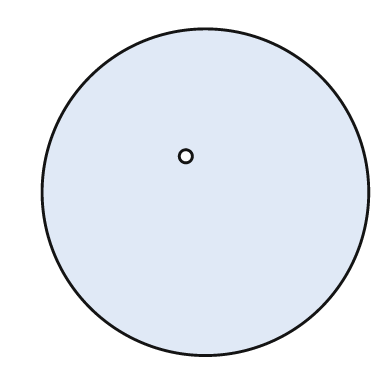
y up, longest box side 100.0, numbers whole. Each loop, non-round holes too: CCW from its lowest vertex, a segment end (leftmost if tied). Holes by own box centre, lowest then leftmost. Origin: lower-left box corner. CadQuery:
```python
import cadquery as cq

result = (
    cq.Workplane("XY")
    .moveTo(50.0, 50.0)
    .circle(50.0)
    .moveTo(44.0, 61.0)
    .circle(2.0)
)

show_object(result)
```